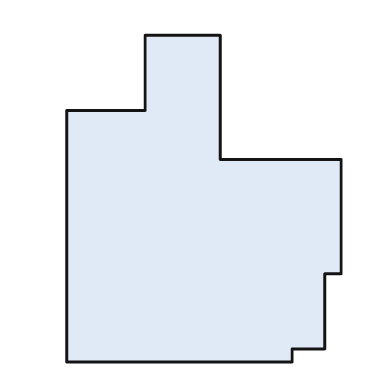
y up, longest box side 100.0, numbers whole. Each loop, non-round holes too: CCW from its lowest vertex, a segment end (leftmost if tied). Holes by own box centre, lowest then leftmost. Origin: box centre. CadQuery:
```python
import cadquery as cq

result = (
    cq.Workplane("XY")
    .moveTo(-42.0, -50.0)
    .lineTo(27.0, -50.0)
    .lineTo(27.0, -46.0)
    .lineTo(37.0, -46.0)
    .lineTo(37.0, -23.0)
    .lineTo(42.0, -23.0)
    .lineTo(42.0, 12.0)
    .lineTo(5.0, 12.0)
    .lineTo(5.0, 50.0)
    .lineTo(-18.0, 50.0)
    .lineTo(-18.0, 27.0)
    .lineTo(-42.0, 27.0)
    .close()
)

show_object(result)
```